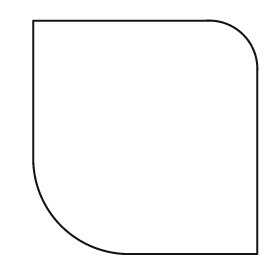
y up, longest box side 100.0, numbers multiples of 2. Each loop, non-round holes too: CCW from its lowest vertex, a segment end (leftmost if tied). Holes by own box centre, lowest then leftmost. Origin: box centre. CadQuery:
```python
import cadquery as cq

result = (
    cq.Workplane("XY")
    .moveTo(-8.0, -50.0)
    .lineTo(48.0, -50.0)
    .lineTo(48.0, 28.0)
    .threePointArc((42.0, 44.0), (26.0, 50.0))
    .lineTo(-48.0, 50.0)
    .lineTo(-48.0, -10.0)
    .threePointArc((-36.0, -38.0), (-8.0, -50.0))
    .close()
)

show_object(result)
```